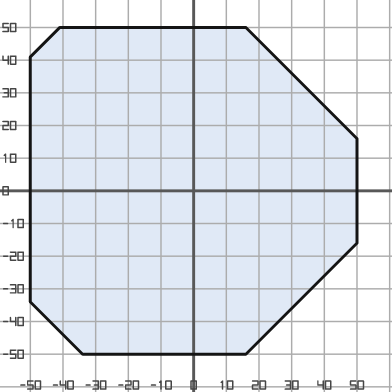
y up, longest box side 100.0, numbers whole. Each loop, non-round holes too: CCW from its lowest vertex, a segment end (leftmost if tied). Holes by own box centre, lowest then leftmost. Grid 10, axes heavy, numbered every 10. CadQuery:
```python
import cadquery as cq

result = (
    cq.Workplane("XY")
    .moveTo(-34.0, -50.0)
    .lineTo(16.0, -50.0)
    .lineTo(50.0, -16.0)
    .lineTo(50.0, 16.0)
    .lineTo(16.0, 50.0)
    .lineTo(-41.0, 50.0)
    .lineTo(-50.0, 41.0)
    .lineTo(-50.0, -34.0)
    .close()
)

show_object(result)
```